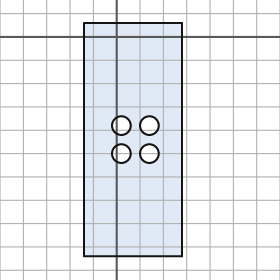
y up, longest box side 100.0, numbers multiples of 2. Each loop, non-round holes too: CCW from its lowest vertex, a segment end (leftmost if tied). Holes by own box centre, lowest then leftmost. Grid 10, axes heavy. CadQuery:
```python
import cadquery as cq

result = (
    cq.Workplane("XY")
    .moveTo(-14.0, -94.0)
    .lineTo(28.0, -94.0)
    .lineTo(28.0, 6.0)
    .lineTo(-14.0, 6.0)
    .close()
    .moveTo(2.0, -50.0)
    .circle(4.0)
    .moveTo(14.0, -50.0)
    .circle(4.0)
    .moveTo(2.0, -38.0)
    .circle(4.0)
    .moveTo(14.0, -38.0)
    .circle(4.0)
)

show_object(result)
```